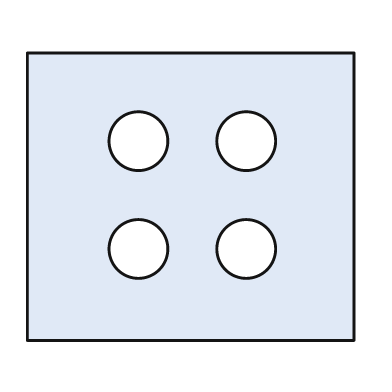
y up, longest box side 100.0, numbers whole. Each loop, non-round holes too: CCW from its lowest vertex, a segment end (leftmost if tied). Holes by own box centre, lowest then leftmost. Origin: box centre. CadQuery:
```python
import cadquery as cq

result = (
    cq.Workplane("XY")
    .moveTo(-50.0, -44.0)
    .lineTo(50.0, -44.0)
    .lineTo(50.0, 44.0)
    .lineTo(-50.0, 44.0)
    .close()
    .moveTo(-16.0, -16.0)
    .circle(9.0)
    .moveTo(17.0, -16.0)
    .circle(9.0)
    .moveTo(-16.0, 17.0)
    .circle(9.0)
    .moveTo(17.0, 17.0)
    .circle(9.0)
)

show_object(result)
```